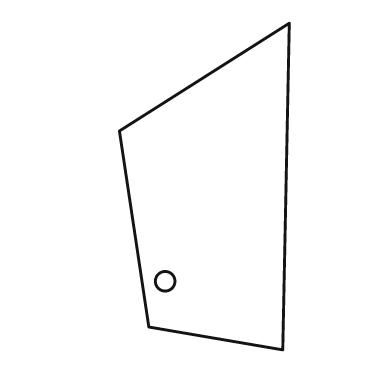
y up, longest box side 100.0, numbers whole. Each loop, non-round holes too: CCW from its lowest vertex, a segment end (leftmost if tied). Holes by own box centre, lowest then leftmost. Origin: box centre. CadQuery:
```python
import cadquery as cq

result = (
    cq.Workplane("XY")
    .moveTo(24.0, -50.0)
    .lineTo(26.0, 50.0)
    .lineTo(-26.0, 17.0)
    .lineTo(-17.0, -43.0)
    .close()
    .moveTo(-12.0, -29.0)
    .circle(3.0)
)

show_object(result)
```